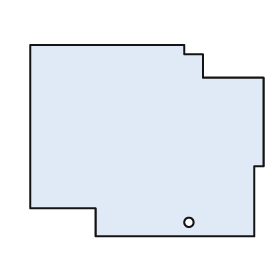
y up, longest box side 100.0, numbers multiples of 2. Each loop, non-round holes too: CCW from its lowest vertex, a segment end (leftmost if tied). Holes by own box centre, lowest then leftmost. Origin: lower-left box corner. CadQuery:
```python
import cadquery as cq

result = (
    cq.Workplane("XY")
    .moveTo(28.0, 0.0)
    .lineTo(96.0, 0.0)
    .lineTo(96.0, 30.0)
    .lineTo(100.0, 30.0)
    .lineTo(100.0, 68.0)
    .lineTo(74.0, 68.0)
    .lineTo(74.0, 78.0)
    .lineTo(66.0, 78.0)
    .lineTo(66.0, 82.0)
    .lineTo(0.0, 82.0)
    .lineTo(0.0, 12.0)
    .lineTo(28.0, 12.0)
    .close()
    .moveTo(68.0, 6.0)
    .circle(2.0)
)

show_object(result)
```